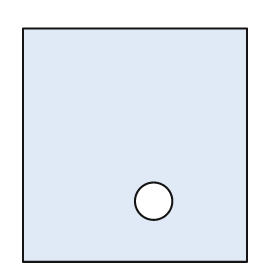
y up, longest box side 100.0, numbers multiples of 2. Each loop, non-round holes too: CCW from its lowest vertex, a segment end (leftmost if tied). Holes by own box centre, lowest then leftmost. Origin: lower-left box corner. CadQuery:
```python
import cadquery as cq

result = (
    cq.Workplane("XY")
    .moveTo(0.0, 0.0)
    .lineTo(96.0, 0.0)
    .lineTo(96.0, 100.0)
    .lineTo(0.0, 100.0)
    .close()
    .moveTo(56.0, 26.0)
    .circle(8.0)
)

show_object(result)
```